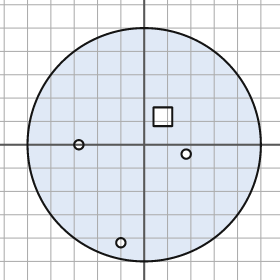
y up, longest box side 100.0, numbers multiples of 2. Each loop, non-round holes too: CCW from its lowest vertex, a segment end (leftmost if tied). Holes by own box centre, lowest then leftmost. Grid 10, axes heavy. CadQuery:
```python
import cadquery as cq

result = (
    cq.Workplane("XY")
    .moveTo(0.0, 0.0)
    .circle(50.0)
    .moveTo(-10.0, -42.0)
    .circle(2.0)
    .moveTo(18.0, -4.0)
    .circle(2.0)
    .moveTo(-28.0, 0.0)
    .circle(2.0)
    .moveTo(4.0, 8.0)
    .lineTo(12.0, 8.0)
    .lineTo(12.0, 16.0)
    .lineTo(4.0, 16.0)
    .close()
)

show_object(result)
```